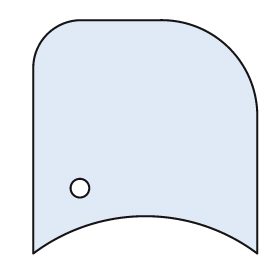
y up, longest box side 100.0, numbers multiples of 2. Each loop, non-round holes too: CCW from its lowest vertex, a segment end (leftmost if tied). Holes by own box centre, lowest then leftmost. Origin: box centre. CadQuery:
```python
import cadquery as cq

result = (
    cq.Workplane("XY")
    .moveTo(-48.0, -50.0)
    .threePointArc((0.0, -34.0), (48.0, -50.0))
    .lineTo(48.0, 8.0)
    .threePointArc((36.0, 38.0), (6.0, 50.0))
    .lineTo(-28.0, 50.0)
    .threePointArc((-42.0, 44.0), (-48.0, 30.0))
    .close()
    .moveTo(-28.0, -22.0)
    .circle(4.0)
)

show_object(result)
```